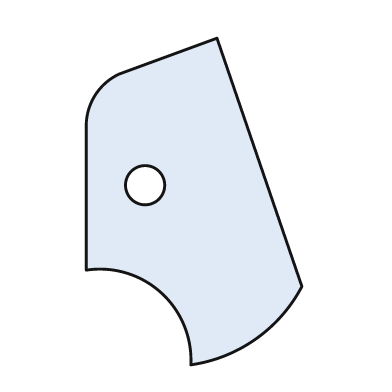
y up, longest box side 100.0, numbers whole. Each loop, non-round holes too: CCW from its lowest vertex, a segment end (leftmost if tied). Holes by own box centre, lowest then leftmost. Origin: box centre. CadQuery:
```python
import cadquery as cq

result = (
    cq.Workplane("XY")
    .moveTo(-1.0, -50.0)
    .threePointArc((19.0, -42.0), (33.0, -26.0))
    .lineTo(7.0, 50.0)
    .lineTo(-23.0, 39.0)
    .threePointArc((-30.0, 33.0), (-33.0, 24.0))
    .lineTo(-33.0, -21.0)
    .threePointArc((-10.0, -28.0), (-1.0, -50.0))
    .close()
    .moveTo(-15.0, 5.0)
    .circle(6.0)
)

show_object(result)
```